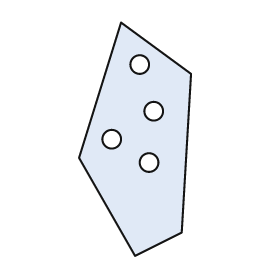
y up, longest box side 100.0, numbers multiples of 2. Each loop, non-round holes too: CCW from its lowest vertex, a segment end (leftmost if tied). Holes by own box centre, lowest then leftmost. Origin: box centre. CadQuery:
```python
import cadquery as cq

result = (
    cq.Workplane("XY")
    .moveTo(0.0, -50.0)
    .lineTo(20.0, -40.0)
    .lineTo(24.0, 28.0)
    .lineTo(-6.0, 50.0)
    .lineTo(-24.0, -8.0)
    .close()
    .moveTo(6.0, -10.0)
    .circle(4.0)
    .moveTo(-10.0, 0.0)
    .circle(4.0)
    .moveTo(8.0, 12.0)
    .circle(4.0)
    .moveTo(2.0, 32.0)
    .circle(4.0)
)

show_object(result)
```